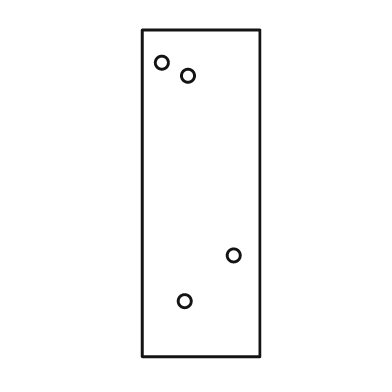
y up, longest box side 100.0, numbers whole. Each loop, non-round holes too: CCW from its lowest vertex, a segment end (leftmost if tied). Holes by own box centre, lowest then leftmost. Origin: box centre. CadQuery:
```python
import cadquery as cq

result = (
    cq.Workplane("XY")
    .moveTo(-18.0, -50.0)
    .lineTo(18.0, -50.0)
    .lineTo(18.0, 50.0)
    .lineTo(-18.0, 50.0)
    .close()
    .moveTo(-5.0, -33.0)
    .circle(2.0)
    .moveTo(10.0, -19.0)
    .circle(2.0)
    .moveTo(-4.0, 36.0)
    .circle(2.0)
    .moveTo(-12.0, 40.0)
    .circle(2.0)
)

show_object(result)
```